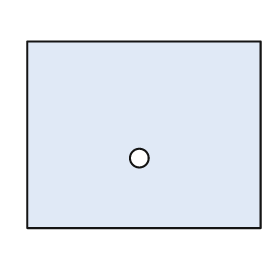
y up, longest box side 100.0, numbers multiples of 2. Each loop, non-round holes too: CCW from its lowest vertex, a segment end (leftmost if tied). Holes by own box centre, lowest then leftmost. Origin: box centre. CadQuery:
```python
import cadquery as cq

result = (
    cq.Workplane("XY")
    .moveTo(-50.0, -40.0)
    .lineTo(50.0, -40.0)
    .lineTo(50.0, 40.0)
    .lineTo(-50.0, 40.0)
    .close()
    .moveTo(-2.0, -10.0)
    .circle(4.0)
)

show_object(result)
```